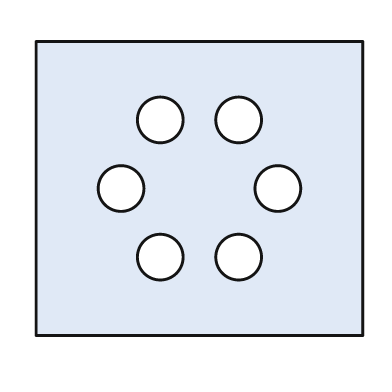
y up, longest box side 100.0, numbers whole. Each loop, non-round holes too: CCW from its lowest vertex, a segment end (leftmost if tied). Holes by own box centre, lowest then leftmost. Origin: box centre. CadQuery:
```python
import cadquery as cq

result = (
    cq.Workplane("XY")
    .moveTo(-50.0, -45.0)
    .lineTo(50.0, -45.0)
    .lineTo(50.0, 45.0)
    .lineTo(-50.0, 45.0)
    .close()
    .moveTo(-12.0, -21.0)
    .circle(7.0)
    .moveTo(12.0, -21.0)
    .circle(7.0)
    .moveTo(-24.0, 0.0)
    .circle(7.0)
    .moveTo(24.0, 0.0)
    .circle(7.0)
    .moveTo(-12.0, 21.0)
    .circle(7.0)
    .moveTo(12.0, 21.0)
    .circle(7.0)
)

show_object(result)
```